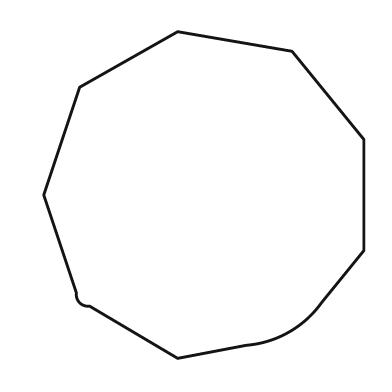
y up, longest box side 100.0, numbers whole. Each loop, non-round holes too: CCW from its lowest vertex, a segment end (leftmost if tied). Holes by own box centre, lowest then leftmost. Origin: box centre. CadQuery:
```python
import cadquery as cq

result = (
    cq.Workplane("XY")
    .moveTo(-8.0, -50.0)
    .lineTo(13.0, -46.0)
    .threePointArc((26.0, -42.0), (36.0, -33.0))
    .lineTo(49.0, -17.0)
    .lineTo(49.0, 17.0)
    .lineTo(27.0, 44.0)
    .lineTo(-8.0, 50.0)
    .lineTo(-38.0, 33.0)
    .lineTo(-49.0, 0.0)
    .lineTo(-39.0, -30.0)
    .threePointArc((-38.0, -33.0), (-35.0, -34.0))
    .close()
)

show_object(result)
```